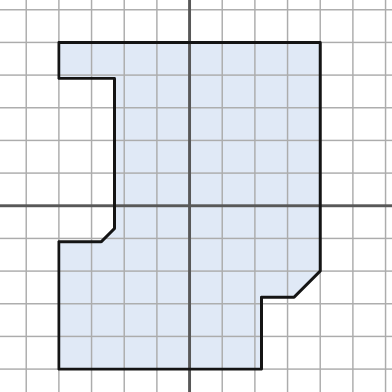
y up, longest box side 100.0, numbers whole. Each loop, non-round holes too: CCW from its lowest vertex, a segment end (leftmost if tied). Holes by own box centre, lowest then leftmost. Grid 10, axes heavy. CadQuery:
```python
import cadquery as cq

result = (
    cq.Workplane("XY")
    .moveTo(-40.0, -50.0)
    .lineTo(22.0, -50.0)
    .lineTo(22.0, -28.0)
    .lineTo(32.0, -28.0)
    .lineTo(40.0, -20.0)
    .lineTo(40.0, 50.0)
    .lineTo(-40.0, 50.0)
    .lineTo(-40.0, 39.0)
    .lineTo(-23.0, 39.0)
    .lineTo(-23.0, -7.0)
    .lineTo(-27.0, -11.0)
    .lineTo(-40.0, -11.0)
    .close()
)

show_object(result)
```